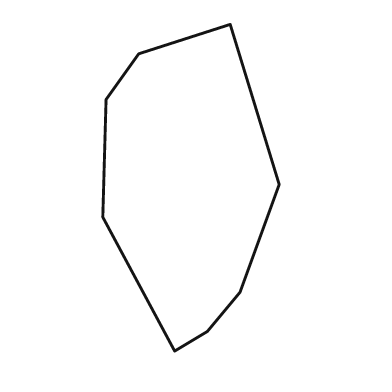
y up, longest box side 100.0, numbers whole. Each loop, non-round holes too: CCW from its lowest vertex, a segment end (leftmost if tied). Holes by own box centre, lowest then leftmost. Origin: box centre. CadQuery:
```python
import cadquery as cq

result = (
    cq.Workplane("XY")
    .moveTo(-5.0, -50.0)
    .lineTo(5.0, -44.0)
    .lineTo(15.0, -32.0)
    .lineTo(27.0, 1.0)
    .lineTo(12.0, 50.0)
    .lineTo(-16.0, 41.0)
    .lineTo(-26.0, 27.0)
    .lineTo(-27.0, -9.0)
    .close()
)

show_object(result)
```